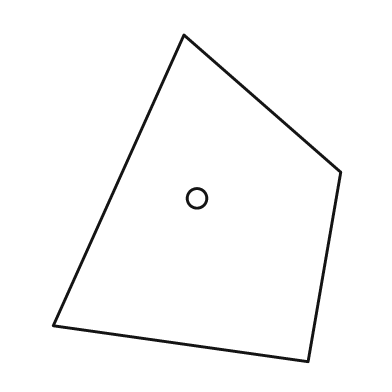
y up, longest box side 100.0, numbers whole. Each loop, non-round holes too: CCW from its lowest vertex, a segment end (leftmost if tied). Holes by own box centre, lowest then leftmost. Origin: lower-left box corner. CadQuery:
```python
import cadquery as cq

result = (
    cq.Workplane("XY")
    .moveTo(78.0, 0.0)
    .lineTo(88.0, 58.0)
    .lineTo(40.0, 100.0)
    .lineTo(0.0, 11.0)
    .close()
    .moveTo(44.0, 50.0)
    .circle(3.0)
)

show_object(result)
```